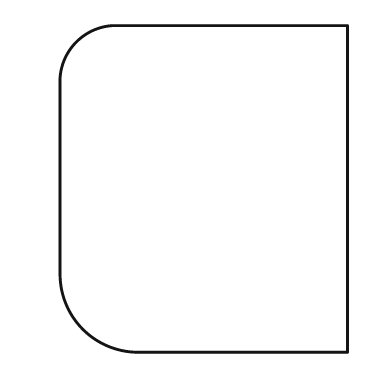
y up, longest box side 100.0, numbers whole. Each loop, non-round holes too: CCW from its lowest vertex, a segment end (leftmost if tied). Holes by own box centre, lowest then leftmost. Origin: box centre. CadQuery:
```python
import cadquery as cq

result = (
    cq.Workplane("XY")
    .moveTo(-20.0, -50.0)
    .lineTo(44.0, -50.0)
    .lineTo(44.0, 50.0)
    .lineTo(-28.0, 50.0)
    .threePointArc((-39.0, 45.0), (-44.0, 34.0))
    .lineTo(-44.0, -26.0)
    .threePointArc((-37.0, -43.0), (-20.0, -50.0))
    .close()
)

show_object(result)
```